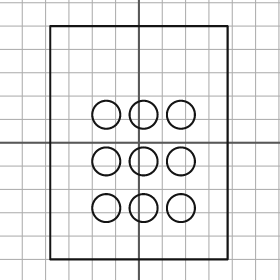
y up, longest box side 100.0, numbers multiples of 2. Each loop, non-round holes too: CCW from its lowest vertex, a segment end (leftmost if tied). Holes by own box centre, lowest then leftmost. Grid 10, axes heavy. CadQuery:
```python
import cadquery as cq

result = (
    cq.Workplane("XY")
    .moveTo(-38.0, -50.0)
    .lineTo(38.0, -50.0)
    .lineTo(38.0, 50.0)
    .lineTo(-38.0, 50.0)
    .close()
    .moveTo(-14.0, -28.0)
    .circle(6.0)
    .moveTo(2.0, -28.0)
    .circle(6.0)
    .moveTo(18.0, -28.0)
    .circle(6.0)
    .moveTo(-14.0, -8.0)
    .circle(6.0)
    .moveTo(2.0, -8.0)
    .circle(6.0)
    .moveTo(18.0, -8.0)
    .circle(6.0)
    .moveTo(-14.0, 12.0)
    .circle(6.0)
    .moveTo(2.0, 12.0)
    .circle(6.0)
    .moveTo(18.0, 12.0)
    .circle(6.0)
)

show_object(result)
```